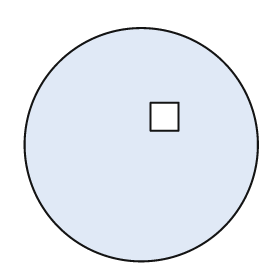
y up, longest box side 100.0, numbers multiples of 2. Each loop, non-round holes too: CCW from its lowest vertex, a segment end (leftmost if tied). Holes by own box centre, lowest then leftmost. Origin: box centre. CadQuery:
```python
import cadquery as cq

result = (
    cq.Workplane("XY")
    .moveTo(0.0, 0.0)
    .circle(50.0)
    .moveTo(4.0, 6.0)
    .lineTo(16.0, 6.0)
    .lineTo(16.0, 18.0)
    .lineTo(4.0, 18.0)
    .close()
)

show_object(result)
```